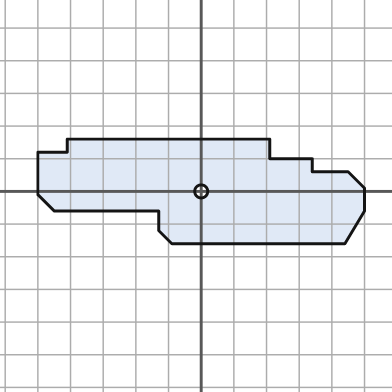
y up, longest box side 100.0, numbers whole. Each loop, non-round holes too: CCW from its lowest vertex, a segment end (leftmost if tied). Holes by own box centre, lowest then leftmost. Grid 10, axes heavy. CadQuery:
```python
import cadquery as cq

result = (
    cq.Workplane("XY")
    .moveTo(-9.0, -16.0)
    .lineTo(44.0, -16.0)
    .lineTo(50.0, -6.0)
    .lineTo(50.0, 1.0)
    .lineTo(45.0, 6.0)
    .lineTo(34.0, 6.0)
    .lineTo(34.0, 10.0)
    .lineTo(21.0, 10.0)
    .lineTo(21.0, 16.0)
    .lineTo(-41.0, 16.0)
    .lineTo(-41.0, 12.0)
    .lineTo(-50.0, 12.0)
    .lineTo(-50.0, -1.0)
    .lineTo(-45.0, -6.0)
    .lineTo(-13.0, -6.0)
    .lineTo(-13.0, -12.0)
    .close()
    .moveTo(0.0, 0.0)
    .circle(2.0)
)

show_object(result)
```